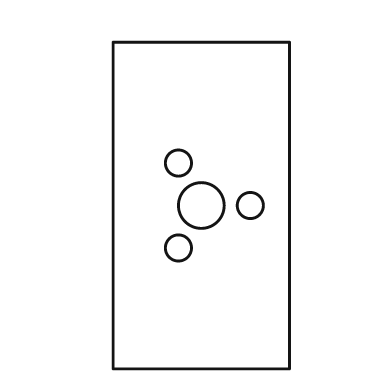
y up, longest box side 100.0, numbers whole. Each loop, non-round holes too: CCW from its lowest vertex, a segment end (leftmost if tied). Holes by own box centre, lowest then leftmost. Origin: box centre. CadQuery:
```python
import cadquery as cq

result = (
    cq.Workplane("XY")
    .moveTo(-27.0, -50.0)
    .lineTo(27.0, -50.0)
    .lineTo(27.0, 50.0)
    .lineTo(-27.0, 50.0)
    .close()
    .moveTo(-7.0, -13.0)
    .circle(4.0)
    .moveTo(0.0, 0.0)
    .circle(7.0)
    .moveTo(15.0, 0.0)
    .circle(4.0)
    .moveTo(-7.0, 13.0)
    .circle(4.0)
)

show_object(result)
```